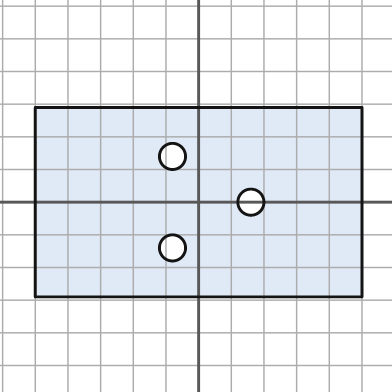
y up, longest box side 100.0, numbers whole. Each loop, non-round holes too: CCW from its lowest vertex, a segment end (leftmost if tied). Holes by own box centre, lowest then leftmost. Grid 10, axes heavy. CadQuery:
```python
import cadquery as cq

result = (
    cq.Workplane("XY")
    .moveTo(-50.0, -29.0)
    .lineTo(50.0, -29.0)
    .lineTo(50.0, 29.0)
    .lineTo(-50.0, 29.0)
    .close()
    .moveTo(-8.0, -14.0)
    .circle(4.0)
    .moveTo(16.0, 0.0)
    .circle(4.0)
    .moveTo(-8.0, 14.0)
    .circle(4.0)
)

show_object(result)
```